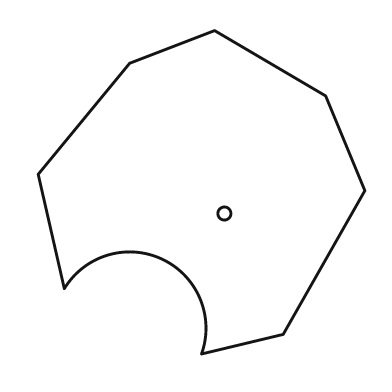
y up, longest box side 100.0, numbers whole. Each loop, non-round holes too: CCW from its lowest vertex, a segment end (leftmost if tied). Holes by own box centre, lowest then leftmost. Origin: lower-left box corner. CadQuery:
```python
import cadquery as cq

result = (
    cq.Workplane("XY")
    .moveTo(50.0, 0.0)
    .lineTo(75.0, 6.0)
    .lineTo(100.0, 50.0)
    .lineTo(88.0, 79.0)
    .lineTo(54.0, 99.0)
    .lineTo(28.0, 89.0)
    .lineTo(0.0, 55.0)
    .lineTo(8.0, 20.0)
    .threePointArc((38.0, 29.0), (50.0, 0.0))
    .close()
    .moveTo(57.0, 43.0)
    .circle(2.0)
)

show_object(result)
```